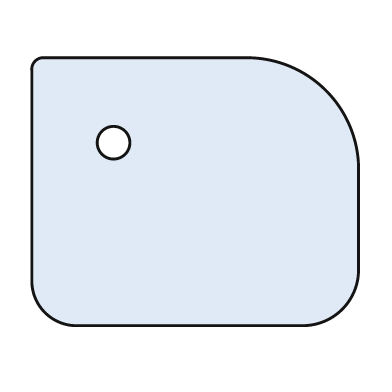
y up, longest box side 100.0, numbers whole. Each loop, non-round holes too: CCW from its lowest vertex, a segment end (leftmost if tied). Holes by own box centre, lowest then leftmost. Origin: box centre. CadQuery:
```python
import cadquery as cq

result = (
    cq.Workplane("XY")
    .moveTo(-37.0, -41.0)
    .lineTo(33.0, -41.0)
    .threePointArc((45.0, -36.0), (50.0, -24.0))
    .lineTo(50.0, 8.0)
    .threePointArc((40.0, 31.0), (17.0, 41.0))
    .lineTo(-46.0, 41.0)
    .threePointArc((-49.0, 40.0), (-50.0, 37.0))
    .lineTo(-50.0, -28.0)
    .threePointArc((-46.0, -37.0), (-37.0, -41.0))
    .close()
    .moveTo(-25.0, 15.0)
    .circle(5.0)
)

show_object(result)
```